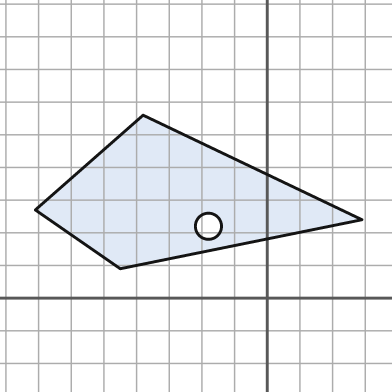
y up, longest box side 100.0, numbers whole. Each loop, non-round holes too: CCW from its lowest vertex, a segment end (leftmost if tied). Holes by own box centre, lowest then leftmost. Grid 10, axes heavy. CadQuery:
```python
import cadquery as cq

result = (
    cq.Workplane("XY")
    .moveTo(-45.0, 9.0)
    .lineTo(29.0, 24.0)
    .lineTo(-38.0, 56.0)
    .lineTo(-71.0, 27.0)
    .close()
    .moveTo(-18.0, 22.0)
    .circle(4.0)
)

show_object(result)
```